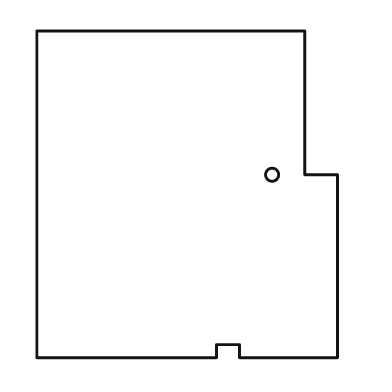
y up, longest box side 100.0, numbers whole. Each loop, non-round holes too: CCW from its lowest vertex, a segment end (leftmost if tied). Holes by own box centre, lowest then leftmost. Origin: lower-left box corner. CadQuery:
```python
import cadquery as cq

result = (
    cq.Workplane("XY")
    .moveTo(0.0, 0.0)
    .lineTo(55.0, 0.0)
    .lineTo(55.0, 4.0)
    .lineTo(62.0, 4.0)
    .lineTo(62.0, 0.0)
    .lineTo(92.0, 0.0)
    .lineTo(92.0, 56.0)
    .lineTo(82.0, 56.0)
    .lineTo(82.0, 100.0)
    .lineTo(0.0, 100.0)
    .close()
    .moveTo(72.0, 56.0)
    .circle(2.0)
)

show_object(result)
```